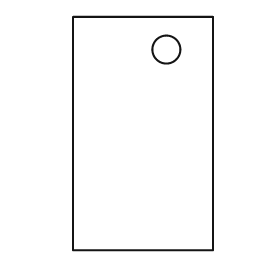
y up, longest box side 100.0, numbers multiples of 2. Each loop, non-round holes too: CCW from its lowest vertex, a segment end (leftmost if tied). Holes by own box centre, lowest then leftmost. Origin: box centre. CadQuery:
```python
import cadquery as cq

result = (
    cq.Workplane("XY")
    .moveTo(-30.0, -50.0)
    .lineTo(30.0, -50.0)
    .lineTo(30.0, 50.0)
    .lineTo(-30.0, 50.0)
    .close()
    .moveTo(10.0, 36.0)
    .circle(6.0)
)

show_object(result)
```